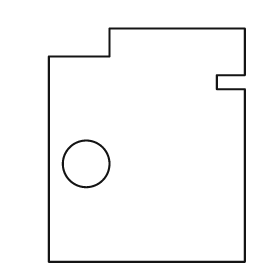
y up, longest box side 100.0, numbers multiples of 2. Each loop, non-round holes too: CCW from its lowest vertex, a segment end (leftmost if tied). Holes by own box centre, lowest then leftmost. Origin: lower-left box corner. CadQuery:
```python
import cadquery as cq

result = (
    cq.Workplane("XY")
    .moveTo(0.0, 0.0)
    .lineTo(84.0, 0.0)
    .lineTo(84.0, 74.0)
    .lineTo(72.0, 74.0)
    .lineTo(72.0, 80.0)
    .lineTo(84.0, 80.0)
    .lineTo(84.0, 100.0)
    .lineTo(26.0, 100.0)
    .lineTo(26.0, 88.0)
    .lineTo(0.0, 88.0)
    .close()
    .moveTo(16.0, 42.0)
    .circle(10.0)
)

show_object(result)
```